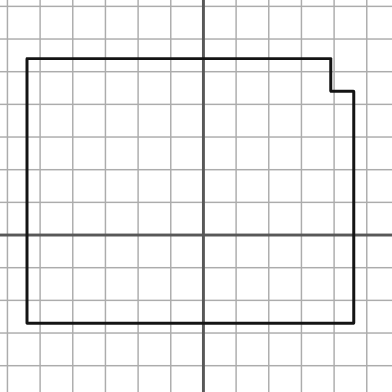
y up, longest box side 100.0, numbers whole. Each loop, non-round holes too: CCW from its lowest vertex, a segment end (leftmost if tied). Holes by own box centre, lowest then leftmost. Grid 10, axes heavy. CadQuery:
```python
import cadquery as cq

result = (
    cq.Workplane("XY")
    .moveTo(-54.0, -27.0)
    .lineTo(46.0, -27.0)
    .lineTo(46.0, 44.0)
    .lineTo(39.0, 44.0)
    .lineTo(39.0, 54.0)
    .lineTo(-54.0, 54.0)
    .close()
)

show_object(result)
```